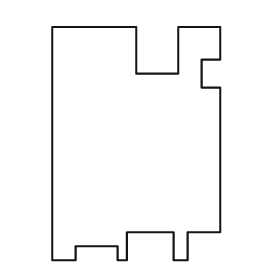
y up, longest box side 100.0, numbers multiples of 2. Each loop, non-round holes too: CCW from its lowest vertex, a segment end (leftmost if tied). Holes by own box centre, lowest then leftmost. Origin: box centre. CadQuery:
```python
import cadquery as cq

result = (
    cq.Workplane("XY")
    .moveTo(-36.0, -50.0)
    .lineTo(-26.0, -50.0)
    .lineTo(-26.0, -44.0)
    .lineTo(-8.0, -44.0)
    .lineTo(-8.0, -50.0)
    .lineTo(-4.0, -50.0)
    .lineTo(-4.0, -38.0)
    .lineTo(16.0, -38.0)
    .lineTo(16.0, -50.0)
    .lineTo(22.0, -50.0)
    .lineTo(22.0, -38.0)
    .lineTo(36.0, -38.0)
    .lineTo(36.0, 24.0)
    .lineTo(28.0, 24.0)
    .lineTo(28.0, 36.0)
    .lineTo(36.0, 36.0)
    .lineTo(36.0, 50.0)
    .lineTo(18.0, 50.0)
    .lineTo(18.0, 30.0)
    .lineTo(0.0, 30.0)
    .lineTo(0.0, 50.0)
    .lineTo(-36.0, 50.0)
    .close()
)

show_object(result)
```